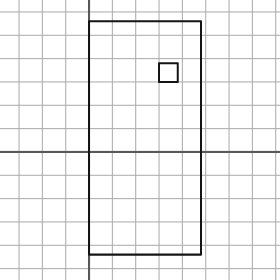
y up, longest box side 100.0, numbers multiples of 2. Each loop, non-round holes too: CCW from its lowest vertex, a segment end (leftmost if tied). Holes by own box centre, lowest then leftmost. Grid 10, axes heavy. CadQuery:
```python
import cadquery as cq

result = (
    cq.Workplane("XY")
    .moveTo(0.0, -44.0)
    .lineTo(48.0, -44.0)
    .lineTo(48.0, 56.0)
    .lineTo(0.0, 56.0)
    .close()
    .moveTo(30.0, 30.0)
    .lineTo(38.0, 30.0)
    .lineTo(38.0, 38.0)
    .lineTo(30.0, 38.0)
    .close()
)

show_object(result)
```